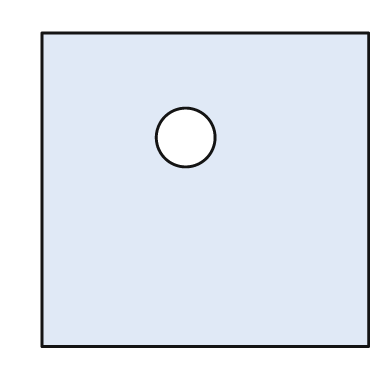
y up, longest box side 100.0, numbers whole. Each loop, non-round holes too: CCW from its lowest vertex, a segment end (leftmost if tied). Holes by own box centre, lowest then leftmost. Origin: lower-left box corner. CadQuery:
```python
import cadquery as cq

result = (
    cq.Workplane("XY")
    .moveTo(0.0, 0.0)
    .lineTo(100.0, 0.0)
    .lineTo(100.0, 96.0)
    .lineTo(0.0, 96.0)
    .close()
    .moveTo(44.0, 64.0)
    .circle(9.0)
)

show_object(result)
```